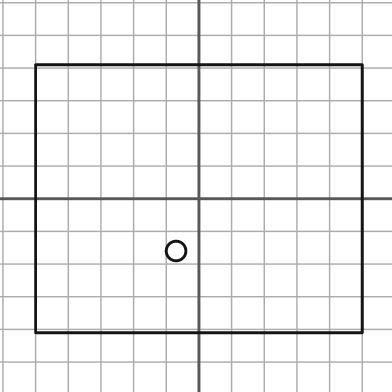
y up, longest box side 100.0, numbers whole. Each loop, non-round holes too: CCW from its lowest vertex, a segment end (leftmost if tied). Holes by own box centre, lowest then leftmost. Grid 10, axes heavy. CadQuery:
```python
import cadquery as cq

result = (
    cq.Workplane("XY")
    .moveTo(-50.0, -41.0)
    .lineTo(50.0, -41.0)
    .lineTo(50.0, 41.0)
    .lineTo(-50.0, 41.0)
    .close()
    .moveTo(-7.0, -16.0)
    .circle(3.0)
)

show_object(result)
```